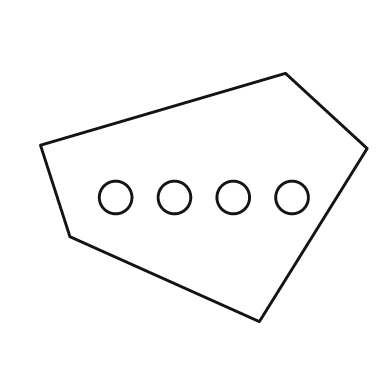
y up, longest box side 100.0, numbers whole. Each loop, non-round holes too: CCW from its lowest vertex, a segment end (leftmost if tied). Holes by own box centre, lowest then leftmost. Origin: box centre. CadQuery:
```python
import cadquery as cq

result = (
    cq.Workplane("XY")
    .moveTo(17.0, -38.0)
    .lineTo(50.0, 15.0)
    .lineTo(25.0, 38.0)
    .lineTo(-50.0, 16.0)
    .lineTo(-41.0, -12.0)
    .close()
    .moveTo(-27.0, 0.0)
    .circle(5.0)
    .moveTo(-9.0, 0.0)
    .circle(5.0)
    .moveTo(9.0, 0.0)
    .circle(5.0)
    .moveTo(27.0, 0.0)
    .circle(5.0)
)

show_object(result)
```